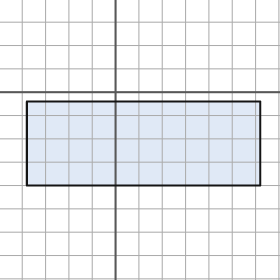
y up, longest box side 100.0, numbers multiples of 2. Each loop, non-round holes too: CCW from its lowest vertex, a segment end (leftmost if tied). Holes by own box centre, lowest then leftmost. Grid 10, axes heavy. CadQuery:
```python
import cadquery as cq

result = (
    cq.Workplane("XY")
    .moveTo(-38.0, -40.0)
    .lineTo(62.0, -40.0)
    .lineTo(62.0, -4.0)
    .lineTo(-38.0, -4.0)
    .close()
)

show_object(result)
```